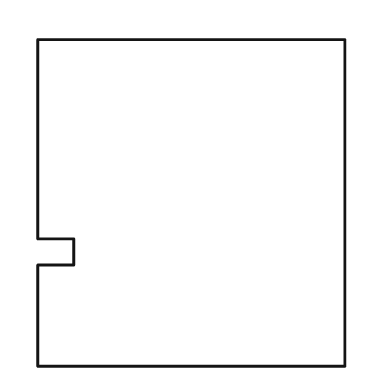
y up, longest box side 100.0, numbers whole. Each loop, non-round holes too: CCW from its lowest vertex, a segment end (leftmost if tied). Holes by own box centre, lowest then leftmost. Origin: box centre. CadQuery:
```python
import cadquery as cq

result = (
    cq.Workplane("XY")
    .moveTo(-47.0, -50.0)
    .lineTo(47.0, -50.0)
    .lineTo(47.0, 50.0)
    .lineTo(-47.0, 50.0)
    .lineTo(-47.0, -11.0)
    .lineTo(-36.0, -11.0)
    .lineTo(-36.0, -19.0)
    .lineTo(-47.0, -19.0)
    .close()
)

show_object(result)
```